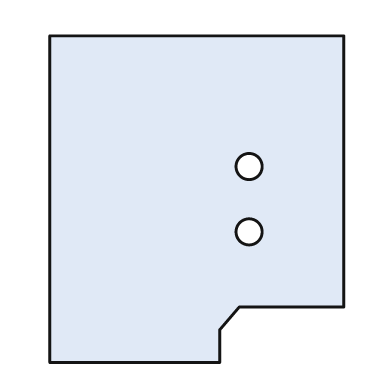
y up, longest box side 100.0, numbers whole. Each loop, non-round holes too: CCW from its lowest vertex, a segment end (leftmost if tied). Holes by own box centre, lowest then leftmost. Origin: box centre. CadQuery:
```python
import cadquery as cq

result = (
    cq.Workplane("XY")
    .moveTo(-45.0, -50.0)
    .lineTo(7.0, -50.0)
    .lineTo(7.0, -40.0)
    .lineTo(13.0, -33.0)
    .lineTo(45.0, -33.0)
    .lineTo(45.0, 50.0)
    .lineTo(-45.0, 50.0)
    .close()
    .moveTo(16.0, -10.0)
    .circle(4.0)
    .moveTo(16.0, 10.0)
    .circle(4.0)
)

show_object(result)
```